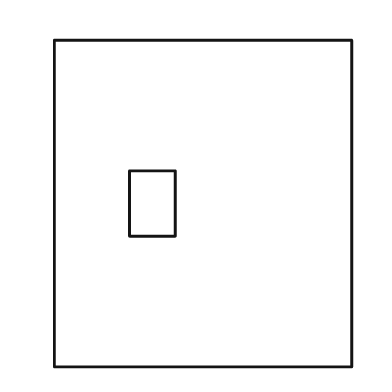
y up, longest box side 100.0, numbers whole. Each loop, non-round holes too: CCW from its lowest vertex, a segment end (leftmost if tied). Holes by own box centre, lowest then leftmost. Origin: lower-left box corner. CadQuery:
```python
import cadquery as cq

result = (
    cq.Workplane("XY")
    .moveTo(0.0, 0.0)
    .lineTo(91.0, 0.0)
    .lineTo(91.0, 100.0)
    .lineTo(0.0, 100.0)
    .close()
    .moveTo(23.0, 40.0)
    .lineTo(37.0, 40.0)
    .lineTo(37.0, 60.0)
    .lineTo(23.0, 60.0)
    .close()
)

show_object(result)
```